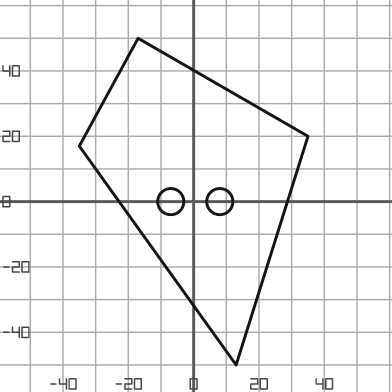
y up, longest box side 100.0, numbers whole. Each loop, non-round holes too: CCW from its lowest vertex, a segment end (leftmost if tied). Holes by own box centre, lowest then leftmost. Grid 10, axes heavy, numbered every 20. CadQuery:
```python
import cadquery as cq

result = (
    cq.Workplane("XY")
    .moveTo(13.0, -50.0)
    .lineTo(35.0, 20.0)
    .lineTo(-17.0, 50.0)
    .lineTo(-35.0, 17.0)
    .close()
    .moveTo(-7.0, 0.0)
    .circle(4.0)
    .moveTo(8.0, 0.0)
    .circle(4.0)
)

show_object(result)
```